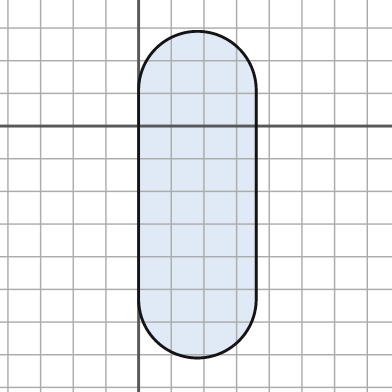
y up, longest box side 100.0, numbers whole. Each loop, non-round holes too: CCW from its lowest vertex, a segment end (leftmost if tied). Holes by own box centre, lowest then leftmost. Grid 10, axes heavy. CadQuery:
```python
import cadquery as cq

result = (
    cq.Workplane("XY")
    .moveTo(0.0, -53.0)
    .threePointArc((18.0, -71.0), (36.0, -53.0))
    .lineTo(36.0, 11.0)
    .threePointArc((18.0, 29.0), (0.0, 11.0))
    .close()
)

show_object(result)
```